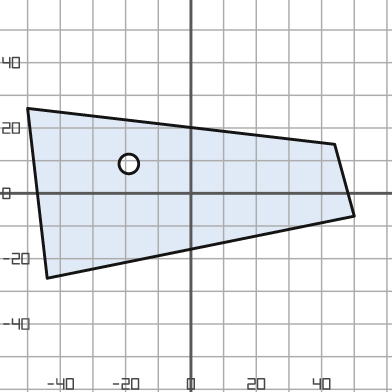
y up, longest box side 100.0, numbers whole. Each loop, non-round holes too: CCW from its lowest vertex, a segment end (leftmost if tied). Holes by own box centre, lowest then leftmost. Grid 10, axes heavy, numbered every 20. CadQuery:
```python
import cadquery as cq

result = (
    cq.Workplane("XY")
    .moveTo(-44.0, -26.0)
    .lineTo(50.0, -7.0)
    .lineTo(44.0, 15.0)
    .lineTo(-50.0, 26.0)
    .close()
    .moveTo(-19.0, 9.0)
    .circle(3.0)
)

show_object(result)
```